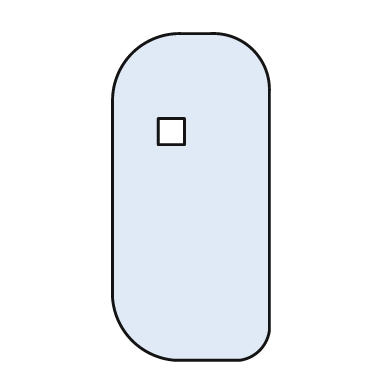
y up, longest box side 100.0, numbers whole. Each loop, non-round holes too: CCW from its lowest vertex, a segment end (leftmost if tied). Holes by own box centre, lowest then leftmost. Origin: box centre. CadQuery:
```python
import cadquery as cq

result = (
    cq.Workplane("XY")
    .moveTo(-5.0, -50.0)
    .lineTo(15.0, -50.0)
    .threePointArc((21.0, -47.0), (24.0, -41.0))
    .lineTo(24.0, 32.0)
    .threePointArc((19.0, 45.0), (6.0, 50.0))
    .lineTo(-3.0, 50.0)
    .threePointArc((-18.0, 44.0), (-24.0, 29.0))
    .lineTo(-24.0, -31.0)
    .threePointArc((-18.0, -44.0), (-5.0, -50.0))
    .close()
    .moveTo(-10.0, 16.0)
    .lineTo(-2.0, 16.0)
    .lineTo(-2.0, 24.0)
    .lineTo(-10.0, 24.0)
    .close()
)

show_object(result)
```